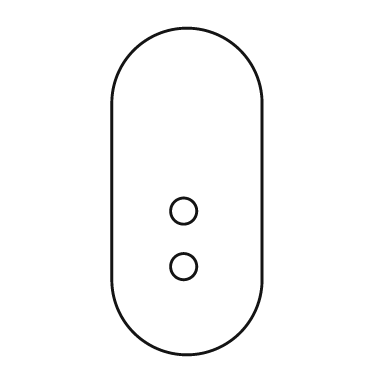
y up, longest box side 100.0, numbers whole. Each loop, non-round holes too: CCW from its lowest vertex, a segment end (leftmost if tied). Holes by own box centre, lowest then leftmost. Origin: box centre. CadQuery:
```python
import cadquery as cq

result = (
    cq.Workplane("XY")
    .moveTo(-23.0, -27.0)
    .threePointArc((0.0, -50.0), (23.0, -27.0))
    .lineTo(23.0, 27.0)
    .threePointArc((0.0, 50.0), (-23.0, 27.0))
    .close()
    .moveTo(-1.0, -23.0)
    .circle(4.0)
    .moveTo(-1.0, -6.0)
    .circle(4.0)
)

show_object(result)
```